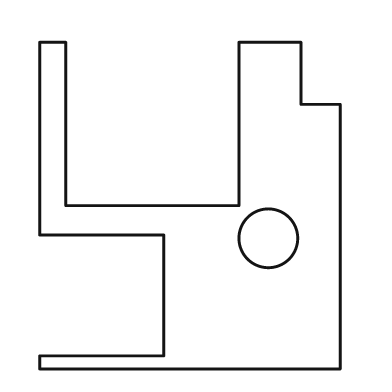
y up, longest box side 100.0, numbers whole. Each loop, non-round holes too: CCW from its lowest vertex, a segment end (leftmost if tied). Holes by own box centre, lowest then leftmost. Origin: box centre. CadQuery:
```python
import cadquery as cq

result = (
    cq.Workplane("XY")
    .moveTo(-46.0, -50.0)
    .lineTo(46.0, -50.0)
    .lineTo(46.0, 31.0)
    .lineTo(34.0, 31.0)
    .lineTo(34.0, 50.0)
    .lineTo(15.0, 50.0)
    .lineTo(15.0, 0.0)
    .lineTo(-38.0, 0.0)
    .lineTo(-38.0, 50.0)
    .lineTo(-46.0, 50.0)
    .lineTo(-46.0, -9.0)
    .lineTo(-8.0, -9.0)
    .lineTo(-8.0, -46.0)
    .lineTo(-46.0, -46.0)
    .close()
    .moveTo(24.0, -10.0)
    .circle(9.0)
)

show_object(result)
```